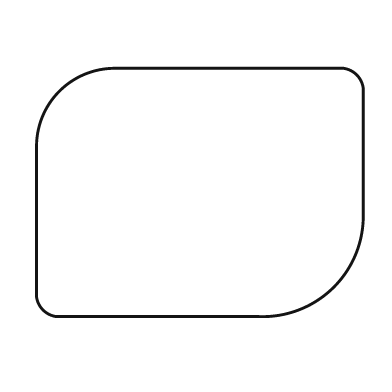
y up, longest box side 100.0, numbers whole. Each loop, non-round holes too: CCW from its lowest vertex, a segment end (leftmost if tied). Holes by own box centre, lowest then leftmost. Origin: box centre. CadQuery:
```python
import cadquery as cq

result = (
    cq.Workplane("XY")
    .moveTo(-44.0, -38.0)
    .lineTo(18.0, -38.0)
    .threePointArc((41.0, -29.0), (50.0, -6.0))
    .lineTo(50.0, 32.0)
    .threePointArc((48.0, 36.0), (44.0, 38.0))
    .lineTo(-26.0, 38.0)
    .threePointArc((-43.0, 31.0), (-50.0, 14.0))
    .lineTo(-50.0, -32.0)
    .threePointArc((-48.0, -36.0), (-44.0, -38.0))
    .close()
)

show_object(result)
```